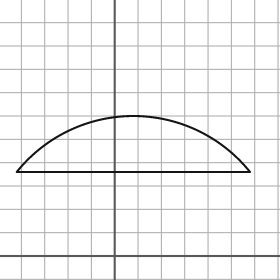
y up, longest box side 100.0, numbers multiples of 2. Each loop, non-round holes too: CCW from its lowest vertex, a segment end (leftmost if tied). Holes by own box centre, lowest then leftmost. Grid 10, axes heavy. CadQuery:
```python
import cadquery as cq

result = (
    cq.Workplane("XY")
    .moveTo(-42.0, 36.0)
    .lineTo(58.0, 36.0)
    .threePointArc((8.0, 60.0), (-42.0, 36.0))
    .close()
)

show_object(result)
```